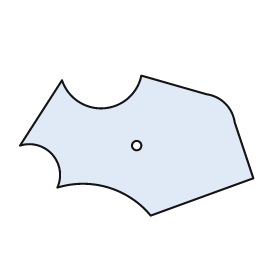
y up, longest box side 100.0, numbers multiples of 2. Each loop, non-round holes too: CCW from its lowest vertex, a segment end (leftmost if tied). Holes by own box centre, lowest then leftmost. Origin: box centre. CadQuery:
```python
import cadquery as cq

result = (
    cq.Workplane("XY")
    .moveTo(6.0, -30.0)
    .lineTo(50.0, -14.0)
    .lineTo(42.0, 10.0)
    .threePointArc((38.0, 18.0), (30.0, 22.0))
    .lineTo(2.0, 30.0)
    .threePointArc((-14.0, 16.0), (-32.0, 28.0))
    .lineTo(-50.0, 0.0)
    .threePointArc((-36.0, -4.0), (-34.0, -18.0))
    .threePointArc((-12.0, -18.0), (6.0, -30.0))
    .close()
    .moveTo(0.0, 0.0)
    .circle(2.0)
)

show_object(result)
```